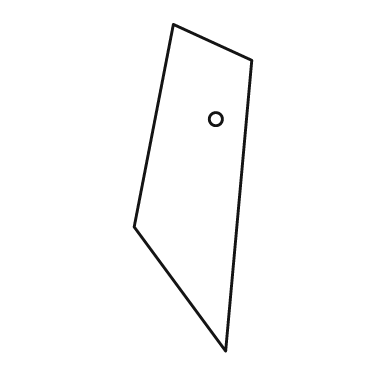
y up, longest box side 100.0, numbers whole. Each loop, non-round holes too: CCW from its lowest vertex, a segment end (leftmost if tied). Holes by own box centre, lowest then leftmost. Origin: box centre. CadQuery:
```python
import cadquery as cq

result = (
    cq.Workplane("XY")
    .moveTo(10.0, -50.0)
    .lineTo(18.0, 39.0)
    .lineTo(-6.0, 50.0)
    .lineTo(-18.0, -12.0)
    .close()
    .moveTo(7.0, 21.0)
    .circle(2.0)
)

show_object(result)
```